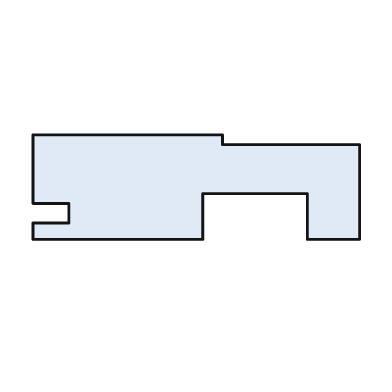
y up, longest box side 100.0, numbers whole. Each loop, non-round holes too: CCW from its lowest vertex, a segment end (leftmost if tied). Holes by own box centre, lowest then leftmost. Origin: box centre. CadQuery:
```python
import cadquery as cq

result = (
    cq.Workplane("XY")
    .moveTo(-50.0, -16.0)
    .lineTo(2.0, -16.0)
    .lineTo(2.0, -2.0)
    .lineTo(34.0, -2.0)
    .lineTo(34.0, -16.0)
    .lineTo(50.0, -16.0)
    .lineTo(50.0, 13.0)
    .lineTo(8.0, 13.0)
    .lineTo(8.0, 16.0)
    .lineTo(-50.0, 16.0)
    .lineTo(-50.0, -5.0)
    .lineTo(-39.0, -5.0)
    .lineTo(-39.0, -11.0)
    .lineTo(-50.0, -11.0)
    .close()
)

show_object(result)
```